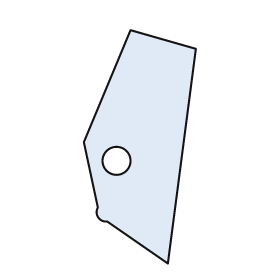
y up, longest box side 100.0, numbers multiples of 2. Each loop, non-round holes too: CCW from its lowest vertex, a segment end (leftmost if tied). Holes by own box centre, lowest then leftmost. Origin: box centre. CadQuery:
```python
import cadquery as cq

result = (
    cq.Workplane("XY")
    .moveTo(12.0, -50.0)
    .lineTo(24.0, 42.0)
    .lineTo(-4.0, 50.0)
    .lineTo(-24.0, 2.0)
    .lineTo(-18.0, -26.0)
    .threePointArc((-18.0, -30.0), (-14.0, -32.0))
    .close()
    .moveTo(-10.0, -6.0)
    .circle(6.0)
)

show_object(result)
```